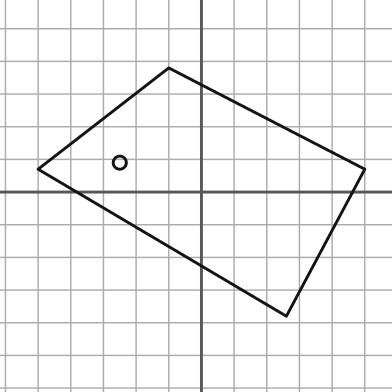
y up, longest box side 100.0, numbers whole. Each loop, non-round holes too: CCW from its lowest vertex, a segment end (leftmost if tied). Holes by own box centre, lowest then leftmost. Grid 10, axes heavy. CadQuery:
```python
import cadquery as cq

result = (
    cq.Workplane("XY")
    .moveTo(26.0, -38.0)
    .lineTo(50.0, 7.0)
    .lineTo(-10.0, 38.0)
    .lineTo(-50.0, 7.0)
    .close()
    .moveTo(-25.0, 9.0)
    .circle(2.0)
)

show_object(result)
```